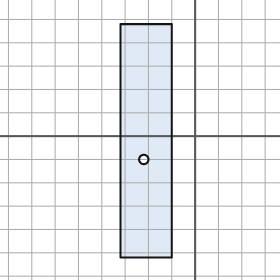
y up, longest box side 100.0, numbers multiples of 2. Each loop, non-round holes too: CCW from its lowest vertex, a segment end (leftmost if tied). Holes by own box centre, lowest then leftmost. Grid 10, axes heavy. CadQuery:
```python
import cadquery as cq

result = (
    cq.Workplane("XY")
    .moveTo(-32.0, -52.0)
    .lineTo(-10.0, -52.0)
    .lineTo(-10.0, 48.0)
    .lineTo(-32.0, 48.0)
    .close()
    .moveTo(-22.0, -10.0)
    .circle(2.0)
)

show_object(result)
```